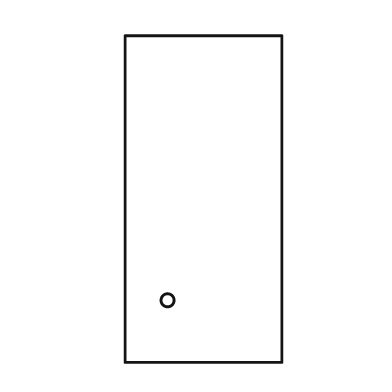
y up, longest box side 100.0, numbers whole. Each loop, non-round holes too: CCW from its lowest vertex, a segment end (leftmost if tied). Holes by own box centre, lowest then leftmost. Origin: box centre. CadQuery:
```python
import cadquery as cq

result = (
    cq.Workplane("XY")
    .moveTo(-24.0, -50.0)
    .lineTo(24.0, -50.0)
    .lineTo(24.0, 50.0)
    .lineTo(-24.0, 50.0)
    .close()
    .moveTo(-11.0, -31.0)
    .circle(2.0)
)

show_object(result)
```